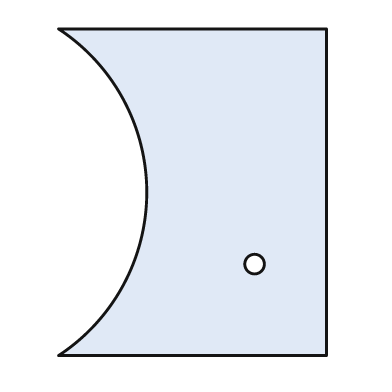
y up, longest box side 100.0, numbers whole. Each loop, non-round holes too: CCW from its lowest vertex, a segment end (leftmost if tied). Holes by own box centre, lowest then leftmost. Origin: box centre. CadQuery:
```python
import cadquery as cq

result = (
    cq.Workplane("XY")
    .moveTo(-41.0, -50.0)
    .lineTo(41.0, -50.0)
    .lineTo(41.0, 50.0)
    .lineTo(-41.0, 50.0)
    .threePointArc((-14.0, 0.0), (-41.0, -50.0))
    .close()
    .moveTo(19.0, -22.0)
    .circle(3.0)
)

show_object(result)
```